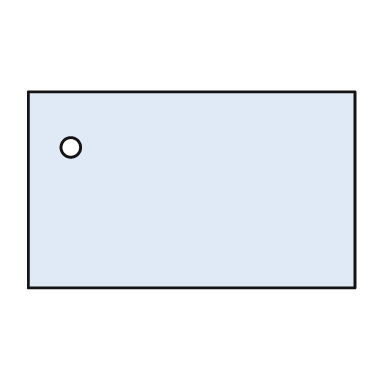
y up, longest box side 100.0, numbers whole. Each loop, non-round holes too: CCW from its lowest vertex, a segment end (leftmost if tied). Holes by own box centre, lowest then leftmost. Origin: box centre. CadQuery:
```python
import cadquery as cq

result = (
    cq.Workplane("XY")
    .moveTo(-50.0, -30.0)
    .lineTo(50.0, -30.0)
    .lineTo(50.0, 30.0)
    .lineTo(-50.0, 30.0)
    .close()
    .moveTo(-37.0, 13.0)
    .circle(3.0)
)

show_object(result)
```